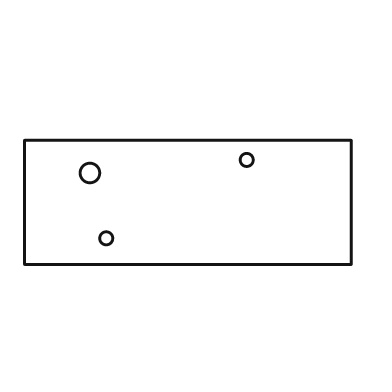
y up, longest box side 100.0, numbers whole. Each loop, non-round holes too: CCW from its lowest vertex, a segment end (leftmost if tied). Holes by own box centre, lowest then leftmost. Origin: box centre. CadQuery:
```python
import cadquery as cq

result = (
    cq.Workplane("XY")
    .moveTo(-50.0, -19.0)
    .lineTo(50.0, -19.0)
    .lineTo(50.0, 19.0)
    .lineTo(-50.0, 19.0)
    .close()
    .moveTo(-25.0, -11.0)
    .circle(2.0)
    .moveTo(-30.0, 9.0)
    .circle(3.0)
    .moveTo(18.0, 13.0)
    .circle(2.0)
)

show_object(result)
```